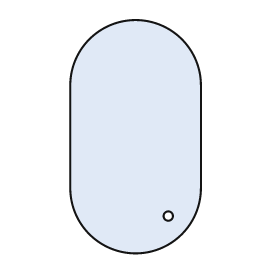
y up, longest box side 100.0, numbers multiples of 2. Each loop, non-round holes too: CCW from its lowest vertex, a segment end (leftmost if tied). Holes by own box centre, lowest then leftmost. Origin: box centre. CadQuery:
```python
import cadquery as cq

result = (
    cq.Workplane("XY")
    .moveTo(-28.0, -22.0)
    .threePointArc((0.0, -50.0), (28.0, -22.0))
    .lineTo(28.0, 22.0)
    .threePointArc((0.0, 50.0), (-28.0, 22.0))
    .close()
    .moveTo(14.0, -34.0)
    .circle(2.0)
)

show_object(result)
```